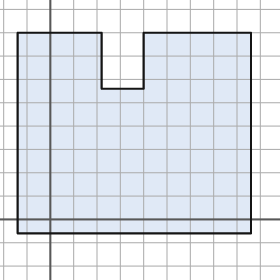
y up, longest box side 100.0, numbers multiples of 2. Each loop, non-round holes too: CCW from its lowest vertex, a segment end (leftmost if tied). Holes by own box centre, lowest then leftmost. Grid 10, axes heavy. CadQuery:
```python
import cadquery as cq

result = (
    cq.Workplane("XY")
    .moveTo(-14.0, -6.0)
    .lineTo(86.0, -6.0)
    .lineTo(86.0, 80.0)
    .lineTo(40.0, 80.0)
    .lineTo(40.0, 56.0)
    .lineTo(22.0, 56.0)
    .lineTo(22.0, 80.0)
    .lineTo(-14.0, 80.0)
    .close()
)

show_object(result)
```